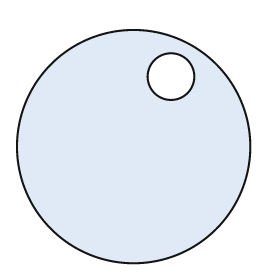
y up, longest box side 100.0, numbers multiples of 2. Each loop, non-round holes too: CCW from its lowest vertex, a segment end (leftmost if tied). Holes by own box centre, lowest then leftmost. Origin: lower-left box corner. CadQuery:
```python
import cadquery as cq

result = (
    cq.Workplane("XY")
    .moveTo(50.0, 50.0)
    .circle(50.0)
    .moveTo(66.0, 80.0)
    .circle(10.0)
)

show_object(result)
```